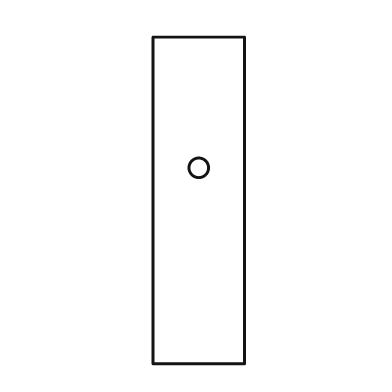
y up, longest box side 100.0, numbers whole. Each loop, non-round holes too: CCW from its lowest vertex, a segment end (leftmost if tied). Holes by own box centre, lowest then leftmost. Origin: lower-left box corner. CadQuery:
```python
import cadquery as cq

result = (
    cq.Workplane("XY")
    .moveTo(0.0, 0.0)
    .lineTo(28.0, 0.0)
    .lineTo(28.0, 100.0)
    .lineTo(0.0, 100.0)
    .close()
    .moveTo(14.0, 60.0)
    .circle(3.0)
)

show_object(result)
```